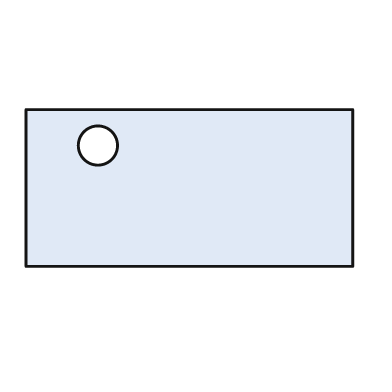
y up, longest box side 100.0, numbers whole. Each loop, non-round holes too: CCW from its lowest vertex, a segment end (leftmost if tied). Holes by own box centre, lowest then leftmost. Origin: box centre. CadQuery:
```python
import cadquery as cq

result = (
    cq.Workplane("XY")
    .moveTo(-50.0, -24.0)
    .lineTo(50.0, -24.0)
    .lineTo(50.0, 24.0)
    .lineTo(-50.0, 24.0)
    .close()
    .moveTo(-28.0, 13.0)
    .circle(6.0)
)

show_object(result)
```